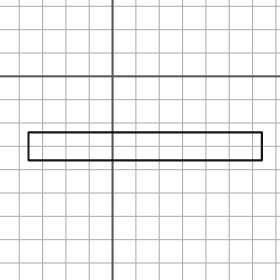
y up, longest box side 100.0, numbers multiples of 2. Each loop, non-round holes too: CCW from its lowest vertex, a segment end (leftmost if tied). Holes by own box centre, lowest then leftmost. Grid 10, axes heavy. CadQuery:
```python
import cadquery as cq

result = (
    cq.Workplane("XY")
    .moveTo(-36.0, -36.0)
    .lineTo(64.0, -36.0)
    .lineTo(64.0, -24.0)
    .lineTo(-36.0, -24.0)
    .close()
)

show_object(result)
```